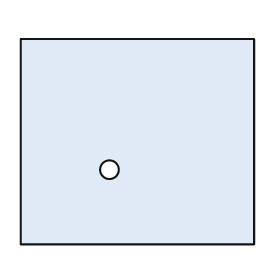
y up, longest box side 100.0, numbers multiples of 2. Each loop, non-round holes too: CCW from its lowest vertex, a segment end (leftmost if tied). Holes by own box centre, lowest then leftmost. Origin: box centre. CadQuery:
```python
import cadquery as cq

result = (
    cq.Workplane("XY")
    .moveTo(-50.0, -44.0)
    .lineTo(50.0, -44.0)
    .lineTo(50.0, 44.0)
    .lineTo(-50.0, 44.0)
    .close()
    .moveTo(-12.0, -12.0)
    .circle(4.0)
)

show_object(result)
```